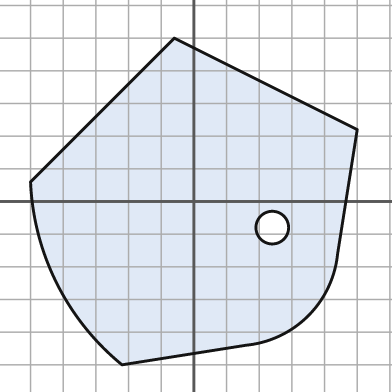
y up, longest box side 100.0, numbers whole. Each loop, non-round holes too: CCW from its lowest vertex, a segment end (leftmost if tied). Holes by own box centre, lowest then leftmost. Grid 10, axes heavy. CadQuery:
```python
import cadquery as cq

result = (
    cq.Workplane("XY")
    .moveTo(-22.0, -50.0)
    .lineTo(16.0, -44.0)
    .threePointArc((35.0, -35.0), (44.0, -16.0))
    .lineTo(50.0, 22.0)
    .lineTo(-6.0, 50.0)
    .lineTo(-50.0, 6.0)
    .threePointArc((-42.0, -25.0), (-22.0, -50.0))
    .close()
    .moveTo(24.0, -8.0)
    .circle(5.0)
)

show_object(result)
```